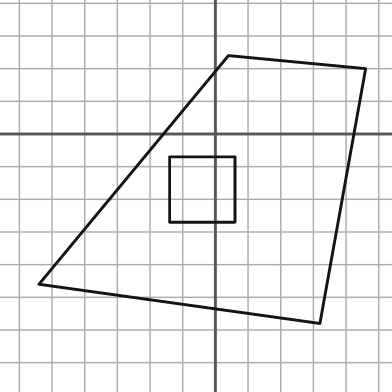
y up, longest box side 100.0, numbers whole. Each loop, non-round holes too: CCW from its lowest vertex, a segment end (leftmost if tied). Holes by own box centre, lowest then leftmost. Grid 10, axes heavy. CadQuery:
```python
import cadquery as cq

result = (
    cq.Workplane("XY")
    .moveTo(32.0, -58.0)
    .lineTo(46.0, 20.0)
    .lineTo(4.0, 24.0)
    .lineTo(-54.0, -46.0)
    .close()
    .moveTo(-14.0, -27.0)
    .lineTo(6.0, -27.0)
    .lineTo(6.0, -7.0)
    .lineTo(-14.0, -7.0)
    .close()
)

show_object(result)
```